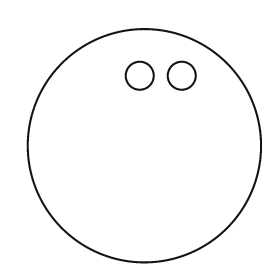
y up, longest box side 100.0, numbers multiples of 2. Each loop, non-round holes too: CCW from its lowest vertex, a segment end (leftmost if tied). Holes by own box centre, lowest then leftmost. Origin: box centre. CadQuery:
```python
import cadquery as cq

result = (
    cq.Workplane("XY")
    .moveTo(0.0, 0.0)
    .circle(50.0)
    .moveTo(-2.0, 30.0)
    .circle(6.0)
    .moveTo(16.0, 30.0)
    .circle(6.0)
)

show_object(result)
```